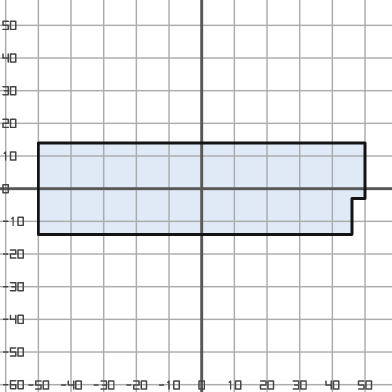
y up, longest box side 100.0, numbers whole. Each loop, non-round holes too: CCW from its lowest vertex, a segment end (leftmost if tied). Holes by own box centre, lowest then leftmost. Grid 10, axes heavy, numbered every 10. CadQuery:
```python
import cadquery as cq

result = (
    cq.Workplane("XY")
    .moveTo(-50.0, -14.0)
    .lineTo(46.0, -14.0)
    .lineTo(46.0, -3.0)
    .lineTo(50.0, -3.0)
    .lineTo(50.0, 14.0)
    .lineTo(-50.0, 14.0)
    .close()
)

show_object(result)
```